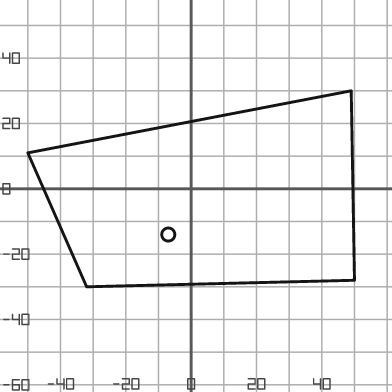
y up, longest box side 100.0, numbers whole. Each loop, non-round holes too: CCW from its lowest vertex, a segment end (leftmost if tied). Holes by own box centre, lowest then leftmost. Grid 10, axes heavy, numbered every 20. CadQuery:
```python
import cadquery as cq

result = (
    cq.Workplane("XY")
    .moveTo(-32.0, -30.0)
    .lineTo(50.0, -28.0)
    .lineTo(49.0, 30.0)
    .lineTo(-50.0, 11.0)
    .close()
    .moveTo(-7.0, -14.0)
    .circle(2.0)
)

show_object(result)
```